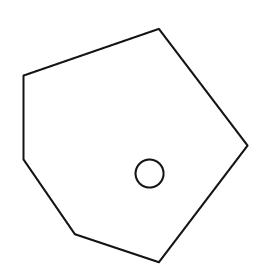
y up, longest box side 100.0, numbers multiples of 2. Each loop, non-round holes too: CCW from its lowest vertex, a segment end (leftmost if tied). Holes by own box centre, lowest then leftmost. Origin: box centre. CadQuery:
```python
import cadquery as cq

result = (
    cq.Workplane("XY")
    .moveTo(10.0, -50.0)
    .lineTo(48.0, 0.0)
    .lineTo(10.0, 50.0)
    .lineTo(-48.0, 30.0)
    .lineTo(-48.0, -6.0)
    .lineTo(-26.0, -38.0)
    .close()
    .moveTo(6.0, -12.0)
    .circle(6.0)
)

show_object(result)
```